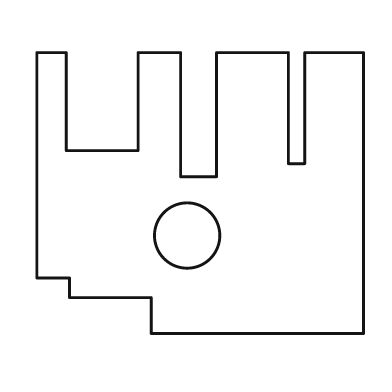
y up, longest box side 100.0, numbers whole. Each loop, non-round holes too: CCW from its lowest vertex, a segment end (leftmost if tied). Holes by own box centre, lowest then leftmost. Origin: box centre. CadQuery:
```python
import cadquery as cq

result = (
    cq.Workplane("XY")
    .moveTo(-15.0, -43.0)
    .lineTo(50.0, -43.0)
    .lineTo(50.0, 43.0)
    .lineTo(32.0, 43.0)
    .lineTo(32.0, 9.0)
    .lineTo(27.0, 9.0)
    .lineTo(27.0, 43.0)
    .lineTo(5.0, 43.0)
    .lineTo(5.0, 5.0)
    .lineTo(-6.0, 5.0)
    .lineTo(-6.0, 43.0)
    .lineTo(-19.0, 43.0)
    .lineTo(-19.0, 13.0)
    .lineTo(-41.0, 13.0)
    .lineTo(-41.0, 43.0)
    .lineTo(-50.0, 43.0)
    .lineTo(-50.0, -26.0)
    .lineTo(-40.0, -26.0)
    .lineTo(-40.0, -32.0)
    .lineTo(-15.0, -32.0)
    .close()
    .moveTo(-4.0, -13.0)
    .circle(10.0)
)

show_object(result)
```